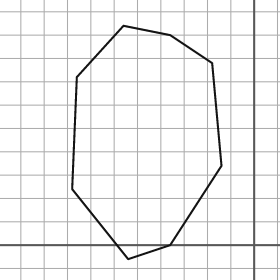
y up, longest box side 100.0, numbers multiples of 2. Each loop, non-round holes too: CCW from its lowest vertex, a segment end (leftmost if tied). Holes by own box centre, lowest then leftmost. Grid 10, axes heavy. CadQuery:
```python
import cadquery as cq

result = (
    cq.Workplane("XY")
    .moveTo(-54.0, -6.0)
    .lineTo(-36.0, 0.0)
    .lineTo(-14.0, 34.0)
    .lineTo(-18.0, 78.0)
    .lineTo(-36.0, 90.0)
    .lineTo(-56.0, 94.0)
    .lineTo(-76.0, 72.0)
    .lineTo(-78.0, 24.0)
    .close()
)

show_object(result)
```